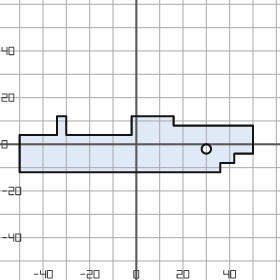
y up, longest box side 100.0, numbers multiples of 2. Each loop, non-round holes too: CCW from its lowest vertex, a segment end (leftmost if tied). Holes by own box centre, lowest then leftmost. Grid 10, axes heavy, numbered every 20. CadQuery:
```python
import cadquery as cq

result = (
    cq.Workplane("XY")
    .moveTo(-50.0, -12.0)
    .lineTo(36.0, -12.0)
    .lineTo(36.0, -8.0)
    .lineTo(42.0, -8.0)
    .lineTo(42.0, -4.0)
    .lineTo(50.0, -4.0)
    .lineTo(50.0, 8.0)
    .lineTo(16.0, 8.0)
    .lineTo(16.0, 12.0)
    .lineTo(-2.0, 12.0)
    .lineTo(-2.0, 4.0)
    .lineTo(-30.0, 4.0)
    .lineTo(-30.0, 12.0)
    .lineTo(-34.0, 12.0)
    .lineTo(-34.0, 4.0)
    .lineTo(-50.0, 4.0)
    .close()
    .moveTo(30.0, -2.0)
    .circle(2.0)
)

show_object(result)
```